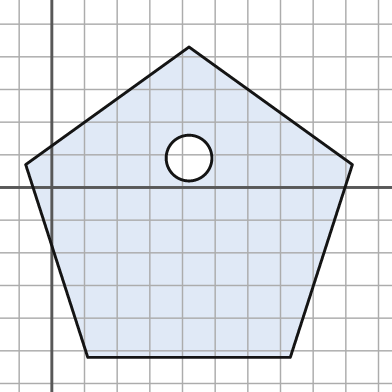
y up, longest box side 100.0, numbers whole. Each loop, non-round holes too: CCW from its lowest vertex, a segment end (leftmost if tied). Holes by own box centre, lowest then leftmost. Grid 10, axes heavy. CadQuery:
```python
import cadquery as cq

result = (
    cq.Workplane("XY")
    .moveTo(11.0, -52.0)
    .lineTo(73.0, -52.0)
    .lineTo(92.0, 7.0)
    .lineTo(42.0, 43.0)
    .lineTo(-8.0, 7.0)
    .close()
    .moveTo(42.0, 9.0)
    .circle(7.0)
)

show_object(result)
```